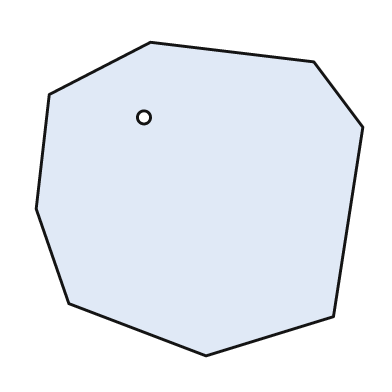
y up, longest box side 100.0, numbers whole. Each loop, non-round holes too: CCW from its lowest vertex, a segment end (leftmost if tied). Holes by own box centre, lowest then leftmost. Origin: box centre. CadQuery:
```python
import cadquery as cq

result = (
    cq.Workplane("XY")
    .moveTo(2.0, -48.0)
    .lineTo(41.0, -36.0)
    .lineTo(50.0, 22.0)
    .lineTo(35.0, 42.0)
    .lineTo(-15.0, 48.0)
    .lineTo(-46.0, 32.0)
    .lineTo(-50.0, -3.0)
    .lineTo(-40.0, -32.0)
    .close()
    .moveTo(-17.0, 25.0)
    .circle(2.0)
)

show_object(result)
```